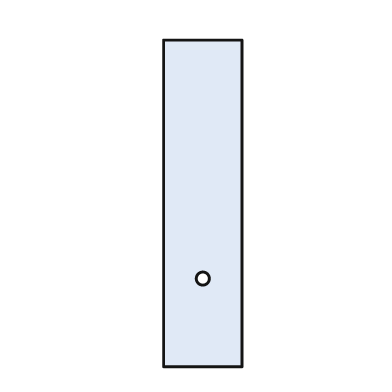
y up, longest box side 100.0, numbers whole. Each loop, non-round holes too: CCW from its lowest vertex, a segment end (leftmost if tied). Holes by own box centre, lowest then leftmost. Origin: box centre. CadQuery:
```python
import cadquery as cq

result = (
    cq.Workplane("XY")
    .moveTo(-12.0, -50.0)
    .lineTo(12.0, -50.0)
    .lineTo(12.0, 50.0)
    .lineTo(-12.0, 50.0)
    .close()
    .moveTo(0.0, -23.0)
    .circle(2.0)
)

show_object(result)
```